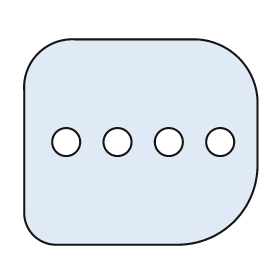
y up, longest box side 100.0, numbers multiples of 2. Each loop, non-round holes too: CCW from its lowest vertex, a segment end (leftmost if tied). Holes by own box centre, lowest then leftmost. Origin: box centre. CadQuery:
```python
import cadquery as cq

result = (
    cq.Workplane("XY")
    .moveTo(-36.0, -44.0)
    .lineTo(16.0, -44.0)
    .threePointArc((40.0, -34.0), (50.0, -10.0))
    .lineTo(50.0, 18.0)
    .threePointArc((42.0, 36.0), (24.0, 44.0))
    .lineTo(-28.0, 44.0)
    .threePointArc((-44.0, 38.0), (-50.0, 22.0))
    .lineTo(-50.0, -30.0)
    .threePointArc((-46.0, -40.0), (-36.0, -44.0))
    .close()
    .moveTo(-32.0, 0.0)
    .circle(6.0)
    .moveTo(-10.0, 0.0)
    .circle(6.0)
    .moveTo(12.0, 0.0)
    .circle(6.0)
    .moveTo(34.0, 0.0)
    .circle(6.0)
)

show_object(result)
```